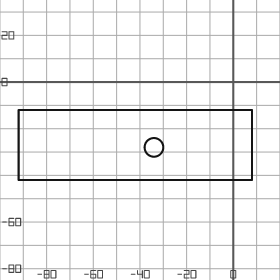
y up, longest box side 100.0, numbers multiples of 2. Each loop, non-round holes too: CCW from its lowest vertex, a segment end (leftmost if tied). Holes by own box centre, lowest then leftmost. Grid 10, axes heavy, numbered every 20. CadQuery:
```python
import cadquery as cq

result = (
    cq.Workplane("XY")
    .moveTo(-92.0, -42.0)
    .lineTo(8.0, -42.0)
    .lineTo(8.0, -12.0)
    .lineTo(-92.0, -12.0)
    .close()
    .moveTo(-34.0, -28.0)
    .circle(4.0)
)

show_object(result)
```